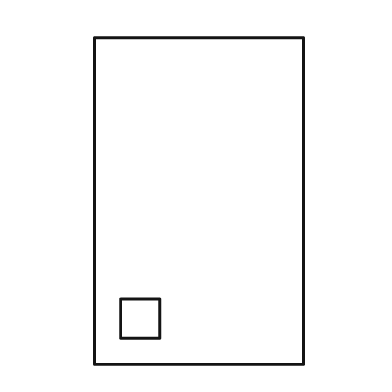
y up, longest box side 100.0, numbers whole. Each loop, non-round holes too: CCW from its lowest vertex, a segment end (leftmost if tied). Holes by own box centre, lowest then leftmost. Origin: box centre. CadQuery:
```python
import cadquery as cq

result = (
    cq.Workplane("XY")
    .moveTo(-32.0, -50.0)
    .lineTo(32.0, -50.0)
    .lineTo(32.0, 50.0)
    .lineTo(-32.0, 50.0)
    .close()
    .moveTo(-24.0, -42.0)
    .lineTo(-12.0, -42.0)
    .lineTo(-12.0, -30.0)
    .lineTo(-24.0, -30.0)
    .close()
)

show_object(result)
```